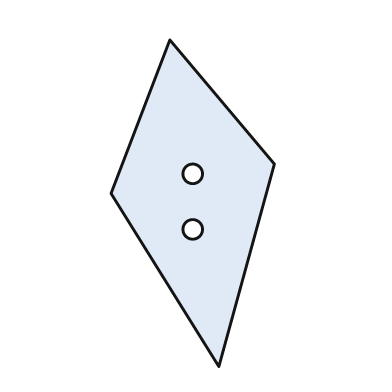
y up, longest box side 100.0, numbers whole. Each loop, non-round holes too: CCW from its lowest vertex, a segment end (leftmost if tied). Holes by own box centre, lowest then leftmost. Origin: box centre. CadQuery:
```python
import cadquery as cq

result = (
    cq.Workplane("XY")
    .moveTo(8.0, -50.0)
    .lineTo(25.0, 12.0)
    .lineTo(-7.0, 50.0)
    .lineTo(-25.0, 3.0)
    .close()
    .moveTo(0.0, -8.0)
    .circle(3.0)
    .moveTo(0.0, 9.0)
    .circle(3.0)
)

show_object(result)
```